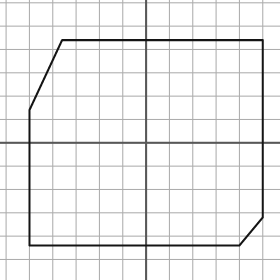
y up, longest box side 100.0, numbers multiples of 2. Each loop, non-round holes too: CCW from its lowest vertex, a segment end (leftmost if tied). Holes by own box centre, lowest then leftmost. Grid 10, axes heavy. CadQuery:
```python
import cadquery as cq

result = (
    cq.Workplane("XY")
    .moveTo(-50.0, -44.0)
    .lineTo(40.0, -44.0)
    .lineTo(50.0, -32.0)
    .lineTo(50.0, 44.0)
    .lineTo(-36.0, 44.0)
    .lineTo(-50.0, 14.0)
    .close()
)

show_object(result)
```